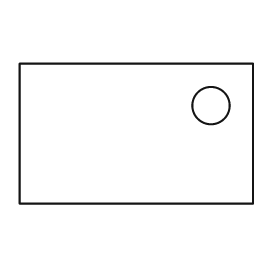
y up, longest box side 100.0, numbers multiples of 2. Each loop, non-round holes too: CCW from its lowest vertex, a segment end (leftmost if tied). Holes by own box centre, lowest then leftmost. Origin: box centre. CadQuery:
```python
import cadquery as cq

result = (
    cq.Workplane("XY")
    .moveTo(-50.0, -30.0)
    .lineTo(50.0, -30.0)
    .lineTo(50.0, 30.0)
    .lineTo(-50.0, 30.0)
    .close()
    .moveTo(32.0, 12.0)
    .circle(8.0)
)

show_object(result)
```